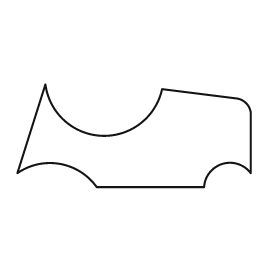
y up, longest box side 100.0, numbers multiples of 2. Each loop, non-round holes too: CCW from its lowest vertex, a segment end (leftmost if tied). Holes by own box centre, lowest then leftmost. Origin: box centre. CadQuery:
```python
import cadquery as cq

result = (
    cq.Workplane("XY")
    .moveTo(-16.0, -22.0)
    .lineTo(30.0, -22.0)
    .threePointArc((38.0, -12.0), (50.0, -16.0))
    .lineTo(50.0, 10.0)
    .threePointArc((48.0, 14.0), (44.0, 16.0))
    .lineTo(12.0, 20.0)
    .threePointArc((-14.0, 0.0), (-38.0, 22.0))
    .lineTo(-50.0, -16.0)
    .threePointArc((-32.0, -12.0), (-16.0, -22.0))
    .close()
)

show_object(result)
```